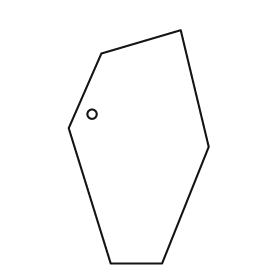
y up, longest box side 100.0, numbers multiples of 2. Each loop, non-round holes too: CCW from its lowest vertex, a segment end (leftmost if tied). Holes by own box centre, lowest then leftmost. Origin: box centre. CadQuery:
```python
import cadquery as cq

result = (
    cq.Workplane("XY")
    .moveTo(-12.0, -50.0)
    .lineTo(10.0, -50.0)
    .lineTo(30.0, 0.0)
    .lineTo(18.0, 50.0)
    .lineTo(-16.0, 40.0)
    .lineTo(-30.0, 8.0)
    .close()
    .moveTo(-20.0, 14.0)
    .circle(2.0)
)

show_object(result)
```